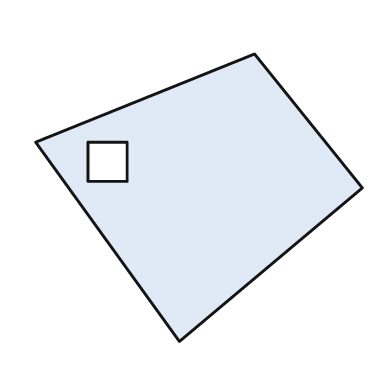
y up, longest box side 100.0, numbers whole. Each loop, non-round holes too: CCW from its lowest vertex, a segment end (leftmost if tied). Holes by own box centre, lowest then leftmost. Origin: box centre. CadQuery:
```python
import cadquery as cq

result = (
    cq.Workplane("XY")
    .moveTo(-6.0, -44.0)
    .lineTo(50.0, 3.0)
    .lineTo(17.0, 44.0)
    .lineTo(-50.0, 17.0)
    .close()
    .moveTo(-34.0, 5.0)
    .lineTo(-22.0, 5.0)
    .lineTo(-22.0, 17.0)
    .lineTo(-34.0, 17.0)
    .close()
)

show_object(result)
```